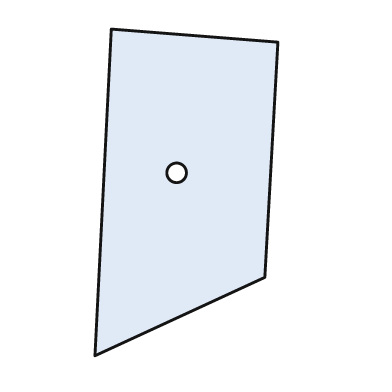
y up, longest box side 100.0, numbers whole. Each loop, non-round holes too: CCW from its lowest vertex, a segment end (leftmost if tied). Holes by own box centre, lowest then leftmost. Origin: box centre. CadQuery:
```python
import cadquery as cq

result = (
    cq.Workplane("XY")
    .moveTo(-28.0, -50.0)
    .lineTo(24.0, -26.0)
    .lineTo(28.0, 46.0)
    .lineTo(-23.0, 50.0)
    .close()
    .moveTo(-3.0, 6.0)
    .circle(3.0)
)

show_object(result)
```